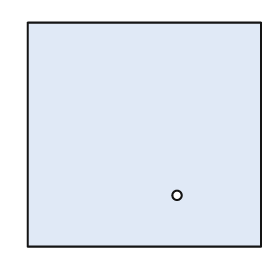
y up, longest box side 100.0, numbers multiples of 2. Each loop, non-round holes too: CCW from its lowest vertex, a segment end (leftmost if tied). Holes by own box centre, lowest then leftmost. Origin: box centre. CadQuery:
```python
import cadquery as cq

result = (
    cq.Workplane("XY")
    .moveTo(-50.0, -48.0)
    .lineTo(50.0, -48.0)
    .lineTo(50.0, 48.0)
    .lineTo(-50.0, 48.0)
    .close()
    .moveTo(14.0, -26.0)
    .circle(2.0)
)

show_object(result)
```